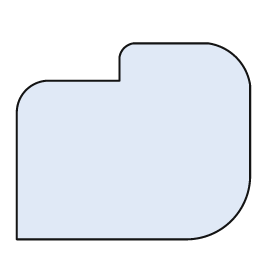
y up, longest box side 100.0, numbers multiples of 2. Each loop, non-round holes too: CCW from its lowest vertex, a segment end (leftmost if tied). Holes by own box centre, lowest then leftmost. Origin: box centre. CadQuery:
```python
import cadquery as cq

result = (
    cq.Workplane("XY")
    .moveTo(-50.0, -42.0)
    .lineTo(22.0, -42.0)
    .threePointArc((42.0, -34.0), (50.0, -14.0))
    .lineTo(50.0, 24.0)
    .threePointArc((44.0, 36.0), (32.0, 42.0))
    .lineTo(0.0, 42.0)
    .threePointArc((-4.0, 40.0), (-6.0, 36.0))
    .lineTo(-6.0, 26.0)
    .lineTo(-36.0, 26.0)
    .threePointArc((-46.0, 22.0), (-50.0, 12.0))
    .close()
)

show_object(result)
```